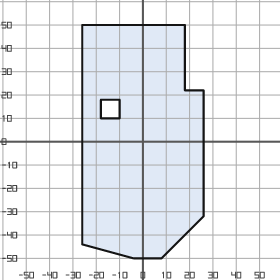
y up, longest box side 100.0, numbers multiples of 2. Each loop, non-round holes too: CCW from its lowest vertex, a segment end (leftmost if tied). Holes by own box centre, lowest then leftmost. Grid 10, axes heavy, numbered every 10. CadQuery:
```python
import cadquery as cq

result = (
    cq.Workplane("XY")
    .moveTo(-4.0, -50.0)
    .lineTo(8.0, -50.0)
    .lineTo(26.0, -32.0)
    .lineTo(26.0, 22.0)
    .lineTo(18.0, 22.0)
    .lineTo(18.0, 50.0)
    .lineTo(-26.0, 50.0)
    .lineTo(-26.0, -44.0)
    .close()
    .moveTo(-18.0, 10.0)
    .lineTo(-10.0, 10.0)
    .lineTo(-10.0, 18.0)
    .lineTo(-18.0, 18.0)
    .close()
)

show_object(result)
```